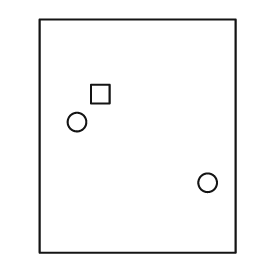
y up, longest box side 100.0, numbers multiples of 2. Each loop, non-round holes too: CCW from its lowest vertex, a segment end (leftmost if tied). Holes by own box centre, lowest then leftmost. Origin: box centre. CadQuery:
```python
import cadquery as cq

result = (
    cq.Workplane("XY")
    .moveTo(-42.0, -50.0)
    .lineTo(42.0, -50.0)
    .lineTo(42.0, 50.0)
    .lineTo(-42.0, 50.0)
    .close()
    .moveTo(30.0, -20.0)
    .circle(4.0)
    .moveTo(-26.0, 6.0)
    .circle(4.0)
    .moveTo(-20.0, 14.0)
    .lineTo(-12.0, 14.0)
    .lineTo(-12.0, 22.0)
    .lineTo(-20.0, 22.0)
    .close()
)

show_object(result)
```